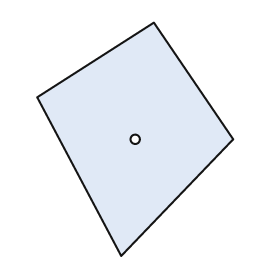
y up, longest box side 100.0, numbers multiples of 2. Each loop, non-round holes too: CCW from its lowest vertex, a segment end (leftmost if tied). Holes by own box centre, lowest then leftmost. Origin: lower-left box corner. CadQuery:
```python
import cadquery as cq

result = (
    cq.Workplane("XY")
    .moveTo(36.0, 0.0)
    .lineTo(84.0, 50.0)
    .lineTo(50.0, 100.0)
    .lineTo(0.0, 68.0)
    .close()
    .moveTo(42.0, 50.0)
    .circle(2.0)
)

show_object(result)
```